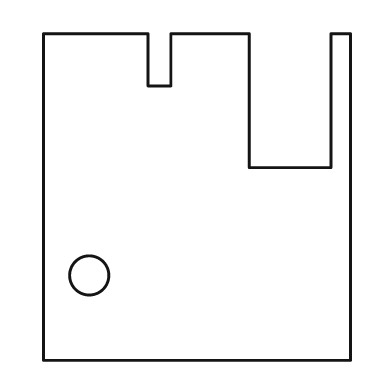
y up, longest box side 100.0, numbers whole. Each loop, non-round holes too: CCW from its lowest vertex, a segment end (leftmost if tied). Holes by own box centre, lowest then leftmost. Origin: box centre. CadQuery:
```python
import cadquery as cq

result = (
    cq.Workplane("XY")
    .moveTo(-47.0, -50.0)
    .lineTo(47.0, -50.0)
    .lineTo(47.0, 50.0)
    .lineTo(41.0, 50.0)
    .lineTo(41.0, 9.0)
    .lineTo(16.0, 9.0)
    .lineTo(16.0, 50.0)
    .lineTo(-8.0, 50.0)
    .lineTo(-8.0, 34.0)
    .lineTo(-15.0, 34.0)
    .lineTo(-15.0, 50.0)
    .lineTo(-47.0, 50.0)
    .close()
    .moveTo(-33.0, -24.0)
    .circle(6.0)
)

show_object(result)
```